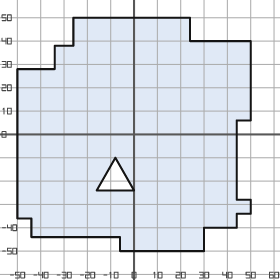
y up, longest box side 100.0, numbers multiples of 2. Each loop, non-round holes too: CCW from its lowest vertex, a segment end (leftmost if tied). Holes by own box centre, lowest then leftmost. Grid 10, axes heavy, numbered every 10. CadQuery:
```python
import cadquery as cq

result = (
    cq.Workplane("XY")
    .moveTo(-6.0, -50.0)
    .lineTo(30.0, -50.0)
    .lineTo(30.0, -40.0)
    .lineTo(44.0, -40.0)
    .lineTo(44.0, -34.0)
    .lineTo(50.0, -34.0)
    .lineTo(50.0, -28.0)
    .lineTo(44.0, -28.0)
    .lineTo(44.0, 6.0)
    .lineTo(50.0, 6.0)
    .lineTo(50.0, 40.0)
    .lineTo(24.0, 40.0)
    .lineTo(24.0, 50.0)
    .lineTo(-26.0, 50.0)
    .lineTo(-26.0, 38.0)
    .lineTo(-34.0, 38.0)
    .lineTo(-34.0, 28.0)
    .lineTo(-50.0, 28.0)
    .lineTo(-50.0, -36.0)
    .lineTo(-44.0, -36.0)
    .lineTo(-44.0, -44.0)
    .lineTo(-6.0, -44.0)
    .close()
    .moveTo(-16.0, -24.0)
    .lineTo(0.0, -24.0)
    .lineTo(-8.0, -10.0)
    .close()
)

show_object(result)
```